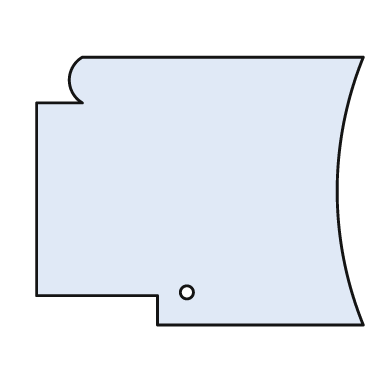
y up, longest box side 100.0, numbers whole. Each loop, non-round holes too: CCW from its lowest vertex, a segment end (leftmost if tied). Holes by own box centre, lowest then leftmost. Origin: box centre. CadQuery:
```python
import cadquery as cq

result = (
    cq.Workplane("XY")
    .moveTo(-13.0, -41.0)
    .lineTo(50.0, -41.0)
    .threePointArc((42.0, 0.0), (50.0, 41.0))
    .lineTo(-36.0, 41.0)
    .threePointArc((-40.0, 34.0), (-36.0, 27.0))
    .lineTo(-50.0, 27.0)
    .lineTo(-50.0, -32.0)
    .lineTo(-13.0, -32.0)
    .close()
    .moveTo(-4.0, -31.0)
    .circle(2.0)
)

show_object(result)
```